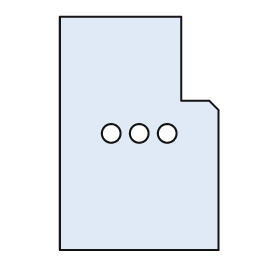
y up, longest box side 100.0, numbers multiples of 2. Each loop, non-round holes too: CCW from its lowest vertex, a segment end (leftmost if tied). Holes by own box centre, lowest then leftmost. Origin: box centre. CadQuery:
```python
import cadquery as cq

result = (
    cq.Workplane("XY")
    .moveTo(-34.0, -50.0)
    .lineTo(34.0, -50.0)
    .lineTo(34.0, 10.0)
    .lineTo(30.0, 14.0)
    .lineTo(18.0, 14.0)
    .lineTo(18.0, 50.0)
    .lineTo(-34.0, 50.0)
    .close()
    .moveTo(-12.0, 0.0)
    .circle(4.0)
    .moveTo(0.0, 0.0)
    .circle(4.0)
    .moveTo(12.0, 0.0)
    .circle(4.0)
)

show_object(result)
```